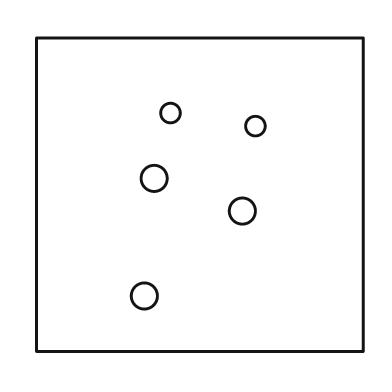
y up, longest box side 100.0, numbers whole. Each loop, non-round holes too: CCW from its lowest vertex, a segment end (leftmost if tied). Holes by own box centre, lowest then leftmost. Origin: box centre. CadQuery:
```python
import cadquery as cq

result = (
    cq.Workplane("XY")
    .moveTo(-50.0, -48.0)
    .lineTo(50.0, -48.0)
    .lineTo(50.0, 48.0)
    .lineTo(-50.0, 48.0)
    .close()
    .moveTo(-17.0, -31.0)
    .circle(4.0)
    .moveTo(13.0, -5.0)
    .circle(4.0)
    .moveTo(-14.0, 5.0)
    .circle(4.0)
    .moveTo(17.0, 21.0)
    .circle(3.0)
    .moveTo(-9.0, 25.0)
    .circle(3.0)
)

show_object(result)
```